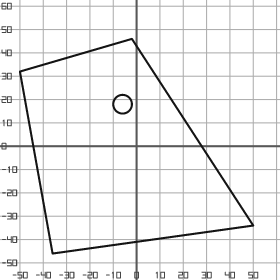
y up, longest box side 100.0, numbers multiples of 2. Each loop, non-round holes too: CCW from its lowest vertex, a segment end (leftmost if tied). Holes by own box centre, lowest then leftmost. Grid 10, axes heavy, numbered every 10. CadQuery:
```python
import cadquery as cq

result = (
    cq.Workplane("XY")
    .moveTo(-36.0, -46.0)
    .lineTo(50.0, -34.0)
    .lineTo(-2.0, 46.0)
    .lineTo(-50.0, 32.0)
    .close()
    .moveTo(-6.0, 18.0)
    .circle(4.0)
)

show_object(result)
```